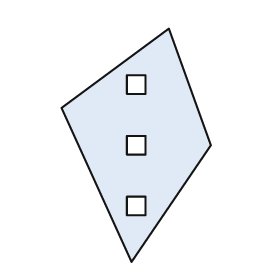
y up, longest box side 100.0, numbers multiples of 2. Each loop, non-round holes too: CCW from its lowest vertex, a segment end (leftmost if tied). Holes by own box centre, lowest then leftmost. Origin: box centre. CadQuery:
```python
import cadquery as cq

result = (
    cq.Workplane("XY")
    .moveTo(-2.0, -50.0)
    .lineTo(32.0, 0.0)
    .lineTo(14.0, 50.0)
    .lineTo(-32.0, 16.0)
    .close()
    .moveTo(-4.0, -30.0)
    .lineTo(4.0, -30.0)
    .lineTo(4.0, -22.0)
    .lineTo(-4.0, -22.0)
    .close()
    .moveTo(-4.0, -4.0)
    .lineTo(4.0, -4.0)
    .lineTo(4.0, 4.0)
    .lineTo(-4.0, 4.0)
    .close()
    .moveTo(-4.0, 22.0)
    .lineTo(4.0, 22.0)
    .lineTo(4.0, 30.0)
    .lineTo(-4.0, 30.0)
    .close()
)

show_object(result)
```